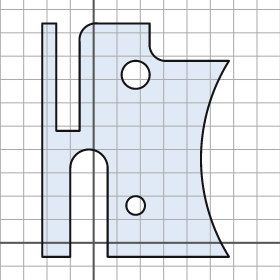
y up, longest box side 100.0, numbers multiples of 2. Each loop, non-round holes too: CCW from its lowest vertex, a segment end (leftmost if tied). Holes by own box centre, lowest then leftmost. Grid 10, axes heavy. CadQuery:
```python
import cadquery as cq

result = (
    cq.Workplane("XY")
    .moveTo(-22.0, -6.0)
    .lineTo(-10.0, -6.0)
    .lineTo(-10.0, 32.0)
    .threePointArc((-2.0, 40.0), (6.0, 32.0))
    .lineTo(6.0, -6.0)
    .lineTo(58.0, -6.0)
    .threePointArc((46.0, 36.0), (58.0, 78.0))
    .lineTo(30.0, 78.0)
    .threePointArc((26.0, 80.0), (24.0, 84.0))
    .lineTo(24.0, 94.0)
    .lineTo(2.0, 94.0)
    .threePointArc((-4.0, 92.0), (-6.0, 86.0))
    .lineTo(-6.0, 48.0)
    .lineTo(-16.0, 48.0)
    .lineTo(-16.0, 94.0)
    .lineTo(-22.0, 94.0)
    .close()
    .moveTo(18.0, 16.0)
    .circle(4.0)
    .moveTo(18.0, 72.0)
    .circle(6.0)
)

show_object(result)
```